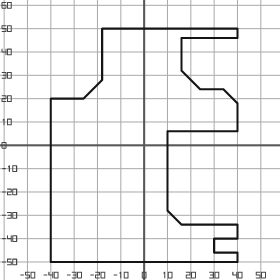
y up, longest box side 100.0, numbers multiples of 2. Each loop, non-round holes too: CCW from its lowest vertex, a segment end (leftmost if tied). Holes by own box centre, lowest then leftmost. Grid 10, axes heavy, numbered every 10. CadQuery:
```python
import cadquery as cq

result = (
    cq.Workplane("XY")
    .moveTo(-40.0, -50.0)
    .lineTo(40.0, -50.0)
    .lineTo(40.0, -46.0)
    .lineTo(30.0, -46.0)
    .lineTo(30.0, -40.0)
    .lineTo(40.0, -40.0)
    .lineTo(40.0, -34.0)
    .lineTo(16.0, -34.0)
    .lineTo(10.0, -28.0)
    .lineTo(10.0, 6.0)
    .lineTo(40.0, 6.0)
    .lineTo(40.0, 18.0)
    .lineTo(34.0, 24.0)
    .lineTo(24.0, 24.0)
    .lineTo(16.0, 32.0)
    .lineTo(16.0, 46.0)
    .lineTo(40.0, 46.0)
    .lineTo(40.0, 50.0)
    .lineTo(-18.0, 50.0)
    .lineTo(-18.0, 28.0)
    .lineTo(-26.0, 20.0)
    .lineTo(-40.0, 20.0)
    .close()
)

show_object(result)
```